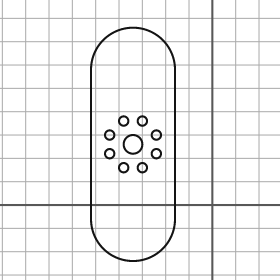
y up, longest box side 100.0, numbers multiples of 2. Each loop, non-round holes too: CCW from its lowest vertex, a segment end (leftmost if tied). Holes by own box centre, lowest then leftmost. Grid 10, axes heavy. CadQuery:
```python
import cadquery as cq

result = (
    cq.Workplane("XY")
    .moveTo(-52.0, -6.0)
    .threePointArc((-34.0, -24.0), (-16.0, -6.0))
    .lineTo(-16.0, 58.0)
    .threePointArc((-34.0, 76.0), (-52.0, 58.0))
    .close()
    .moveTo(-38.0, 16.0)
    .circle(2.0)
    .moveTo(-30.0, 16.0)
    .circle(2.0)
    .moveTo(-44.0, 22.0)
    .circle(2.0)
    .moveTo(-24.0, 22.0)
    .circle(2.0)
    .moveTo(-34.0, 26.0)
    .circle(4.0)
    .moveTo(-44.0, 30.0)
    .circle(2.0)
    .moveTo(-24.0, 30.0)
    .circle(2.0)
    .moveTo(-38.0, 36.0)
    .circle(2.0)
    .moveTo(-30.0, 36.0)
    .circle(2.0)
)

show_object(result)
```